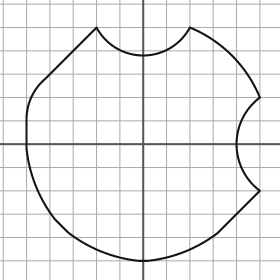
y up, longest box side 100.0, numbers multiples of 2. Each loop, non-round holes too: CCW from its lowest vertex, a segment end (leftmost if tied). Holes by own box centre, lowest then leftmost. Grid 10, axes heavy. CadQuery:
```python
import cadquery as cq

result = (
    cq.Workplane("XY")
    .moveTo(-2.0, -50.0)
    .lineTo(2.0, -50.0)
    .threePointArc((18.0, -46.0), (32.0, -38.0))
    .lineTo(50.0, -20.0)
    .threePointArc((40.0, 0.0), (50.0, 20.0))
    .threePointArc((38.0, 38.0), (20.0, 50.0))
    .threePointArc((0.0, 38.0), (-20.0, 50.0))
    .lineTo(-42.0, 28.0)
    .threePointArc((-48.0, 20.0), (-50.0, 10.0))
    .lineTo(-50.0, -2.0)
    .threePointArc((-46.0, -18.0), (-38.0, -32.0))
    .lineTo(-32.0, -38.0)
    .threePointArc((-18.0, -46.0), (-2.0, -50.0))
    .close()
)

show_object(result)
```